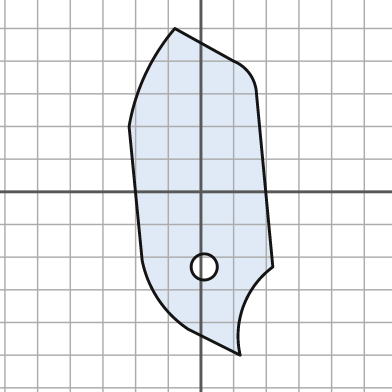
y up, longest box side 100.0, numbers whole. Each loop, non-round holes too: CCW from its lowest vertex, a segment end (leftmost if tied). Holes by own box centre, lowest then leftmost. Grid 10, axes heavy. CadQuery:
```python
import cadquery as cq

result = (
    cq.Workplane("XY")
    .moveTo(12.0, -50.0)
    .threePointArc((13.0, -35.0), (22.0, -23.0))
    .lineTo(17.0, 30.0)
    .threePointArc((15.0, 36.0), (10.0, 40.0))
    .lineTo(-8.0, 50.0)
    .threePointArc((-17.0, 36.0), (-22.0, 20.0))
    .lineTo(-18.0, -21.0)
    .threePointArc((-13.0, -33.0), (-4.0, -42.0))
    .close()
    .moveTo(1.0, -23.0)
    .circle(4.0)
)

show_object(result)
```